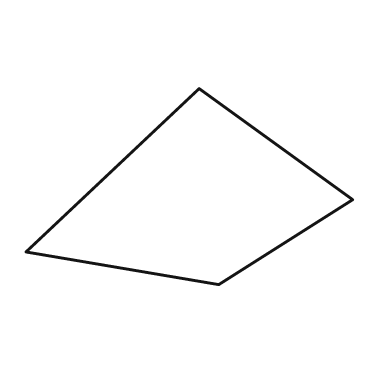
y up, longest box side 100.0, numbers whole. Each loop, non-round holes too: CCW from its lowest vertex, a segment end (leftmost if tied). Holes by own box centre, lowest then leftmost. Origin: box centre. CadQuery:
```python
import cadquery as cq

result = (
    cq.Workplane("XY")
    .moveTo(9.0, -30.0)
    .lineTo(50.0, -4.0)
    .lineTo(3.0, 30.0)
    .lineTo(-50.0, -20.0)
    .close()
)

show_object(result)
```